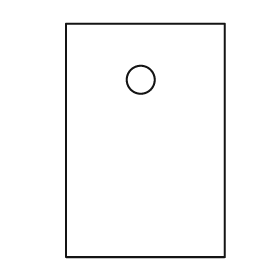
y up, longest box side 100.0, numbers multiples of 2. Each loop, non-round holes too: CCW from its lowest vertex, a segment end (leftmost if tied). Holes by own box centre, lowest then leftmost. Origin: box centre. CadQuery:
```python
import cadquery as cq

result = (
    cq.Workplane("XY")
    .moveTo(-34.0, -50.0)
    .lineTo(34.0, -50.0)
    .lineTo(34.0, 50.0)
    .lineTo(-34.0, 50.0)
    .close()
    .moveTo(-2.0, 26.0)
    .circle(6.0)
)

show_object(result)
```